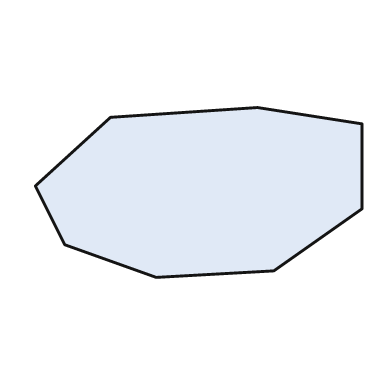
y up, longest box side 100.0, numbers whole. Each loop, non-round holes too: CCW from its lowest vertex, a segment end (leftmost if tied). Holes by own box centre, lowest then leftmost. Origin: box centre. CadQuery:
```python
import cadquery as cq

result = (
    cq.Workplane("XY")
    .moveTo(-13.0, -26.0)
    .lineTo(23.0, -24.0)
    .lineTo(50.0, -5.0)
    .lineTo(50.0, 21.0)
    .lineTo(18.0, 26.0)
    .lineTo(-27.0, 23.0)
    .lineTo(-50.0, 2.0)
    .lineTo(-41.0, -16.0)
    .close()
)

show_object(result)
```